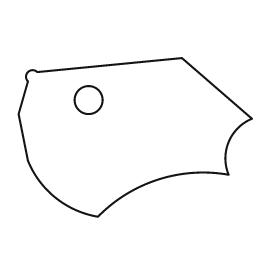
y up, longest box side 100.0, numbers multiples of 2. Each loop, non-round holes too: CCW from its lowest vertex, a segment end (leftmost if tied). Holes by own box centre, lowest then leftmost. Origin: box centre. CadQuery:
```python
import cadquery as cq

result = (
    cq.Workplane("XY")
    .moveTo(-16.0, -34.0)
    .threePointArc((10.0, -18.0), (40.0, -16.0))
    .threePointArc((40.0, -2.0), (50.0, 8.0))
    .lineTo(20.0, 34.0)
    .lineTo(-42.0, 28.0)
    .threePointArc((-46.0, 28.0), (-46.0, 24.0))
    .lineTo(-50.0, 10.0)
    .lineTo(-46.0, -10.0)
    .threePointArc((-34.0, -26.0), (-16.0, -34.0))
    .close()
    .moveTo(-20.0, 16.0)
    .circle(6.0)
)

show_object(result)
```